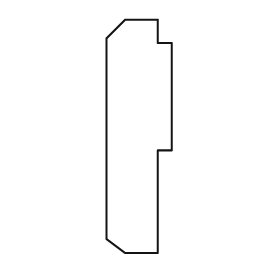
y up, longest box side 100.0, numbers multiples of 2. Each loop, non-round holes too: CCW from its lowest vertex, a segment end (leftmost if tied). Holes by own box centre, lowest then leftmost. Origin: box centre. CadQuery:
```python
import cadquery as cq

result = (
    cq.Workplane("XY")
    .moveTo(-6.0, -50.0)
    .lineTo(8.0, -50.0)
    .lineTo(8.0, -6.0)
    .lineTo(14.0, -6.0)
    .lineTo(14.0, 40.0)
    .lineTo(8.0, 40.0)
    .lineTo(8.0, 50.0)
    .lineTo(-6.0, 50.0)
    .lineTo(-14.0, 42.0)
    .lineTo(-14.0, -44.0)
    .close()
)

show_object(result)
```